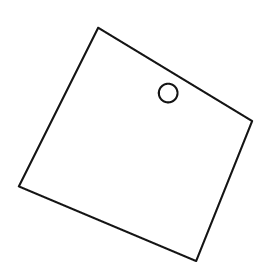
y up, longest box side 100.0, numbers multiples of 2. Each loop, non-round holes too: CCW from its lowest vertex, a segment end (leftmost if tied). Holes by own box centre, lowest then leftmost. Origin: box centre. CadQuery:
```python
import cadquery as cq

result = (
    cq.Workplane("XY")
    .moveTo(26.0, -50.0)
    .lineTo(50.0, 10.0)
    .lineTo(-16.0, 50.0)
    .lineTo(-50.0, -18.0)
    .close()
    .moveTo(14.0, 22.0)
    .circle(4.0)
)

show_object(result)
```